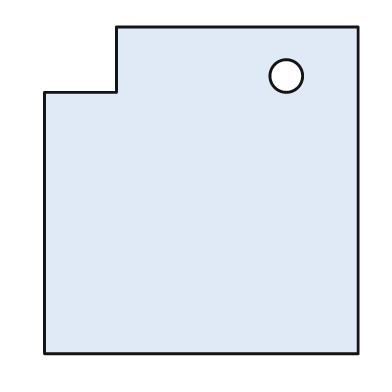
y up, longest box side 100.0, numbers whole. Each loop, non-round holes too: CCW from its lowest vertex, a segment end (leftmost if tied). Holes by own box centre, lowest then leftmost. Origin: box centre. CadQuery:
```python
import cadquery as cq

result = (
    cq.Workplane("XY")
    .moveTo(-48.0, -50.0)
    .lineTo(48.0, -50.0)
    .lineTo(48.0, 50.0)
    .lineTo(-26.0, 50.0)
    .lineTo(-26.0, 30.0)
    .lineTo(-48.0, 30.0)
    .close()
    .moveTo(26.0, 35.0)
    .circle(5.0)
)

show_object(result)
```